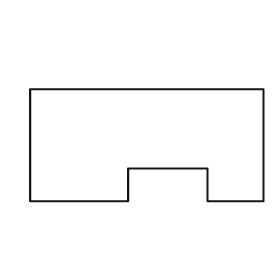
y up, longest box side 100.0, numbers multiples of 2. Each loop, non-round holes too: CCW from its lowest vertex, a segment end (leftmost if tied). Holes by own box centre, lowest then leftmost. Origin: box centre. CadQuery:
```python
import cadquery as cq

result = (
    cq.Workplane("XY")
    .moveTo(-50.0, -24.0)
    .lineTo(-8.0, -24.0)
    .lineTo(-8.0, -10.0)
    .lineTo(26.0, -10.0)
    .lineTo(26.0, -24.0)
    .lineTo(50.0, -24.0)
    .lineTo(50.0, 24.0)
    .lineTo(-50.0, 24.0)
    .close()
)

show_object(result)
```